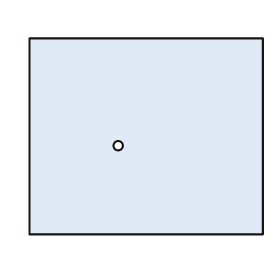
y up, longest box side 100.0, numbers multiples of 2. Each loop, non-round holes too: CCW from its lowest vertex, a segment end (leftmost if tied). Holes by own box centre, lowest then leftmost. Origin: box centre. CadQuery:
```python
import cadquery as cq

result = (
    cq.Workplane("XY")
    .moveTo(-50.0, -42.0)
    .lineTo(50.0, -42.0)
    .lineTo(50.0, 42.0)
    .lineTo(-50.0, 42.0)
    .close()
    .moveTo(-12.0, -4.0)
    .circle(2.0)
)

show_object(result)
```